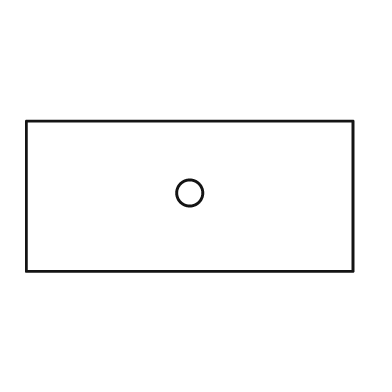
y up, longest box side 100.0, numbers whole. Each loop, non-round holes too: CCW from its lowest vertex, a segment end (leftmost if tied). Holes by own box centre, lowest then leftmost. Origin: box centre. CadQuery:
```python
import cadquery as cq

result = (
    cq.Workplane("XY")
    .moveTo(-50.0, -23.0)
    .lineTo(50.0, -23.0)
    .lineTo(50.0, 23.0)
    .lineTo(-50.0, 23.0)
    .close()
    .moveTo(0.0, 1.0)
    .circle(4.0)
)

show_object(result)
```